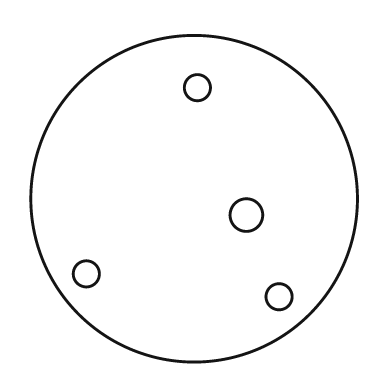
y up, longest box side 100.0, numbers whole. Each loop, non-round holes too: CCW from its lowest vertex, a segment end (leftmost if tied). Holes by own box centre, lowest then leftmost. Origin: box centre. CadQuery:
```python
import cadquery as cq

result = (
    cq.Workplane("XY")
    .moveTo(0.0, 0.0)
    .circle(50.0)
    .moveTo(26.0, -30.0)
    .circle(4.0)
    .moveTo(-33.0, -23.0)
    .circle(4.0)
    .moveTo(16.0, -5.0)
    .circle(5.0)
    .moveTo(1.0, 34.0)
    .circle(4.0)
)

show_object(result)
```